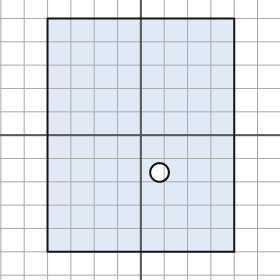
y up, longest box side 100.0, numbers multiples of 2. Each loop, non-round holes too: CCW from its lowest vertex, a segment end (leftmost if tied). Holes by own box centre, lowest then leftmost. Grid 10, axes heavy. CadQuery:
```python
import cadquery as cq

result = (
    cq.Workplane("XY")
    .moveTo(-40.0, -50.0)
    .lineTo(40.0, -50.0)
    .lineTo(40.0, 50.0)
    .lineTo(-40.0, 50.0)
    .close()
    .moveTo(8.0, -16.0)
    .circle(4.0)
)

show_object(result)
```